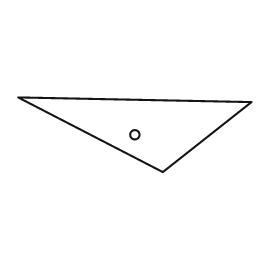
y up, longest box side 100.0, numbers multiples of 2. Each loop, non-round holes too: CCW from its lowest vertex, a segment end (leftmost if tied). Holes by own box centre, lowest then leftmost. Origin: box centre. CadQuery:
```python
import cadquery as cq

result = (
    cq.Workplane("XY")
    .moveTo(12.0, -16.0)
    .lineTo(50.0, 14.0)
    .lineTo(-50.0, 16.0)
    .close()
    .moveTo(0.0, 0.0)
    .circle(2.0)
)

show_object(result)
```